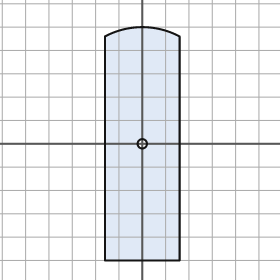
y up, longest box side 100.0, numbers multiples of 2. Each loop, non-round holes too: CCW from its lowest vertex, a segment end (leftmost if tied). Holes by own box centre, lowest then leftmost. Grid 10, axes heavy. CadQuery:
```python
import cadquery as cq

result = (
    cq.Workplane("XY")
    .moveTo(-16.0, -50.0)
    .lineTo(16.0, -50.0)
    .lineTo(16.0, 46.0)
    .threePointArc((0.0, 50.0), (-16.0, 46.0))
    .close()
    .moveTo(0.0, 0.0)
    .circle(2.0)
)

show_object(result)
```